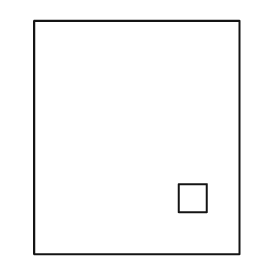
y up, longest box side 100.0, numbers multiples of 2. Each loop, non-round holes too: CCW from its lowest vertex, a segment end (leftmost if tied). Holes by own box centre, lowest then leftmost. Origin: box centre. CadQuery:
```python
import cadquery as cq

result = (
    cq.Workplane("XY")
    .moveTo(-44.0, -50.0)
    .lineTo(44.0, -50.0)
    .lineTo(44.0, 50.0)
    .lineTo(-44.0, 50.0)
    .close()
    .moveTo(18.0, -32.0)
    .lineTo(30.0, -32.0)
    .lineTo(30.0, -20.0)
    .lineTo(18.0, -20.0)
    .close()
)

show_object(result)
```